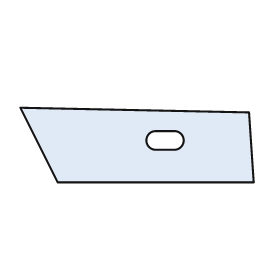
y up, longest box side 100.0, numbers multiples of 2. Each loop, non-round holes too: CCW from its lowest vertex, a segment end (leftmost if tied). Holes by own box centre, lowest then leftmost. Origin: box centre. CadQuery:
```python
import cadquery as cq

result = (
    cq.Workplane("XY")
    .moveTo(-34.0, -16.0)
    .lineTo(50.0, -16.0)
    .lineTo(48.0, 14.0)
    .lineTo(-50.0, 16.0)
    .close()
    .moveTo(8.0, -2.0)
    .lineTo(16.0, -2.0)
    .threePointArc((20.0, 2.0), (16.0, 6.0))
    .lineTo(8.0, 6.0)
    .threePointArc((4.0, 2.0), (8.0, -2.0))
    .close()
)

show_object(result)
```